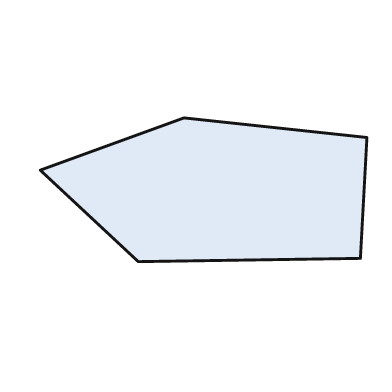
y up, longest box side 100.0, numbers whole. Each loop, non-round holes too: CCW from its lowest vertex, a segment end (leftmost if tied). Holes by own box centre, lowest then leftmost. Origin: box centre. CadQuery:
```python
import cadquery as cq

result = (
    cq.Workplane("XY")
    .moveTo(-20.0, -22.0)
    .lineTo(48.0, -21.0)
    .lineTo(50.0, 16.0)
    .lineTo(-6.0, 22.0)
    .lineTo(-50.0, 6.0)
    .close()
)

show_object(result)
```